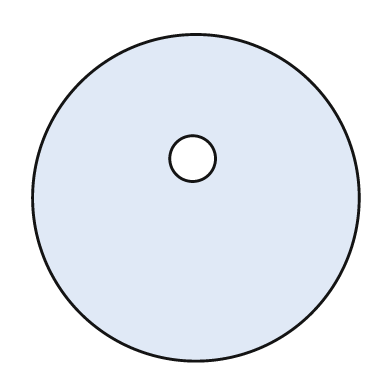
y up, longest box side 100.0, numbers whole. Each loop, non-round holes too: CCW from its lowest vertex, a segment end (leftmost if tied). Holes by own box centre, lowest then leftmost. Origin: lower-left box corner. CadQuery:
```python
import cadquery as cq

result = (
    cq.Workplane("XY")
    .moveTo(50.0, 50.0)
    .circle(50.0)
    .moveTo(49.0, 62.0)
    .circle(7.0)
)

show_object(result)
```